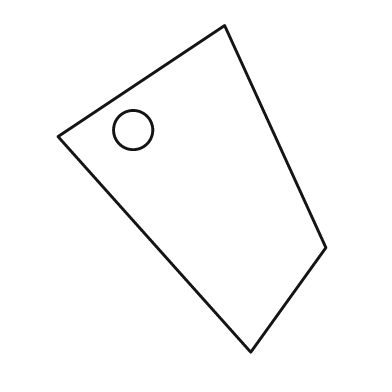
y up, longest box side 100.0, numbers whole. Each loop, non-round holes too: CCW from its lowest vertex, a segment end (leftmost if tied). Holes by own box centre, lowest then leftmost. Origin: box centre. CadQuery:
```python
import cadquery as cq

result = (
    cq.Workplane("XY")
    .moveTo(18.0, -50.0)
    .lineTo(41.0, -18.0)
    .lineTo(10.0, 50.0)
    .lineTo(-41.0, 16.0)
    .close()
    .moveTo(-18.0, 18.0)
    .circle(6.0)
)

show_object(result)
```